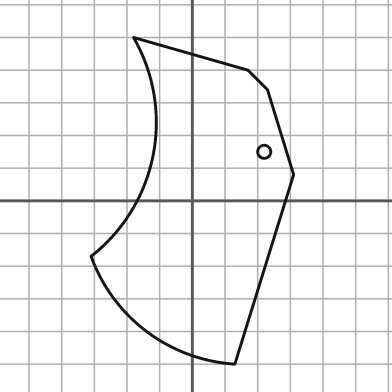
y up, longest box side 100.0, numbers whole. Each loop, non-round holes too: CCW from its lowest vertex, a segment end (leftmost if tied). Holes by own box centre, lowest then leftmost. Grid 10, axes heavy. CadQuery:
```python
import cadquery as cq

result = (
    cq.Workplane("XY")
    .moveTo(13.0, -50.0)
    .lineTo(31.0, 8.0)
    .lineTo(23.0, 34.0)
    .lineTo(17.0, 40.0)
    .lineTo(-18.0, 50.0)
    .threePointArc((-12.0, 14.0), (-31.0, -17.0))
    .threePointArc((-14.0, -40.0), (13.0, -50.0))
    .close()
    .moveTo(22.0, 15.0)
    .circle(2.0)
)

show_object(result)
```